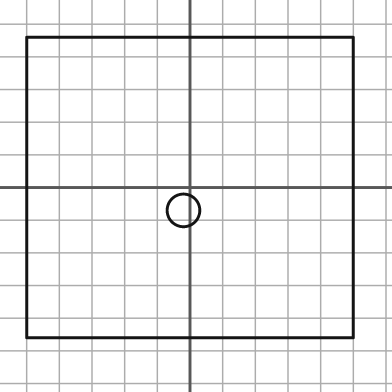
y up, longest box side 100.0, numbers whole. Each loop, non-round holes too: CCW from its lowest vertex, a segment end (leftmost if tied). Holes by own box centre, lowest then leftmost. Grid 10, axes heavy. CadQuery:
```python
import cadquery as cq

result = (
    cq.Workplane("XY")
    .moveTo(-50.0, -46.0)
    .lineTo(50.0, -46.0)
    .lineTo(50.0, 46.0)
    .lineTo(-50.0, 46.0)
    .close()
    .moveTo(-2.0, -7.0)
    .circle(5.0)
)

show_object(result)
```